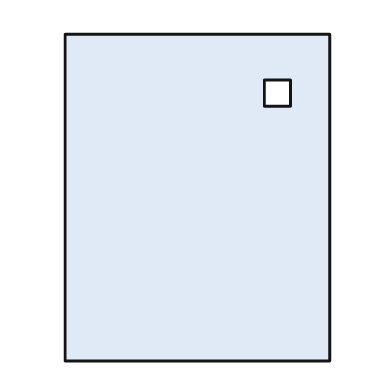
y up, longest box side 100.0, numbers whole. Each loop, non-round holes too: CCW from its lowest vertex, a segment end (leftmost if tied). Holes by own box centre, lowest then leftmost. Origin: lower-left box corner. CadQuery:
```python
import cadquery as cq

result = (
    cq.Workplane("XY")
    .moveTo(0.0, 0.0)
    .lineTo(81.0, 0.0)
    .lineTo(81.0, 100.0)
    .lineTo(0.0, 100.0)
    .close()
    .moveTo(61.0, 78.0)
    .lineTo(69.0, 78.0)
    .lineTo(69.0, 86.0)
    .lineTo(61.0, 86.0)
    .close()
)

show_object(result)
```